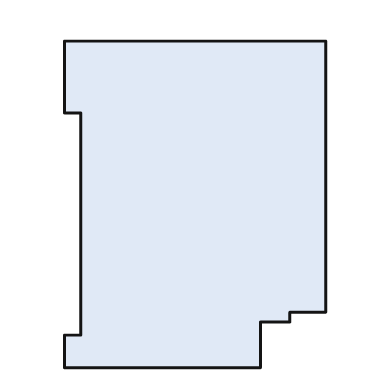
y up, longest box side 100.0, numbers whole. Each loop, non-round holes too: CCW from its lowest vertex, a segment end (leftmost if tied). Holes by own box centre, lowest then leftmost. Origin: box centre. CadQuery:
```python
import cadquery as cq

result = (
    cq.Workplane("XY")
    .moveTo(-40.0, -50.0)
    .lineTo(20.0, -50.0)
    .lineTo(20.0, -36.0)
    .lineTo(29.0, -36.0)
    .lineTo(29.0, -33.0)
    .lineTo(40.0, -33.0)
    .lineTo(40.0, 50.0)
    .lineTo(-40.0, 50.0)
    .lineTo(-40.0, 28.0)
    .lineTo(-35.0, 28.0)
    .lineTo(-35.0, -40.0)
    .lineTo(-40.0, -40.0)
    .close()
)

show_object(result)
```